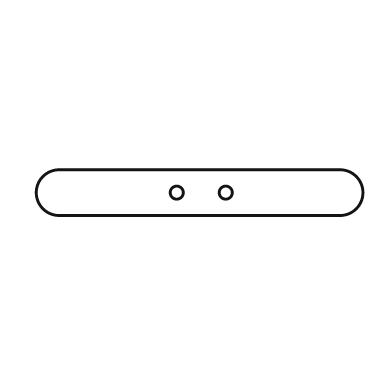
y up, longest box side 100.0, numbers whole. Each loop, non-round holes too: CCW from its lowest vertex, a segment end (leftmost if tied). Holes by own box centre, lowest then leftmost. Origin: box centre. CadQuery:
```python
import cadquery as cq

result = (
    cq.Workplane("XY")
    .moveTo(-43.0, -7.0)
    .lineTo(43.0, -7.0)
    .threePointArc((50.0, 0.0), (43.0, 7.0))
    .lineTo(-43.0, 7.0)
    .threePointArc((-50.0, 0.0), (-43.0, -7.0))
    .close()
    .moveTo(-7.0, 0.0)
    .circle(2.0)
    .moveTo(8.0, 0.0)
    .circle(2.0)
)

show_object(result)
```